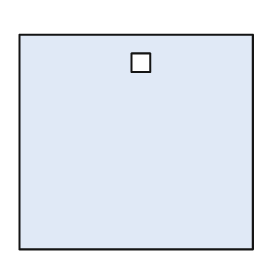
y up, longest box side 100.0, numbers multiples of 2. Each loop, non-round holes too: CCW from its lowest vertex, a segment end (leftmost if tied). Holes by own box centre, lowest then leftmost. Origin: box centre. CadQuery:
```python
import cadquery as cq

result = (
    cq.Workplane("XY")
    .moveTo(-50.0, -46.0)
    .lineTo(50.0, -46.0)
    .lineTo(50.0, 46.0)
    .lineTo(-50.0, 46.0)
    .close()
    .moveTo(-2.0, 30.0)
    .lineTo(6.0, 30.0)
    .lineTo(6.0, 38.0)
    .lineTo(-2.0, 38.0)
    .close()
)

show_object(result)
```